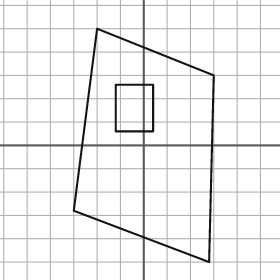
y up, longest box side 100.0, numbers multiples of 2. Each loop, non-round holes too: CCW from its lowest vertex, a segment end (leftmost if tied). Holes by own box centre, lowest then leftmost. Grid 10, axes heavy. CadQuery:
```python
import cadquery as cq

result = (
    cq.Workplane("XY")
    .moveTo(28.0, -50.0)
    .lineTo(30.0, 30.0)
    .lineTo(-20.0, 50.0)
    .lineTo(-30.0, -28.0)
    .close()
    .moveTo(-12.0, 6.0)
    .lineTo(4.0, 6.0)
    .lineTo(4.0, 26.0)
    .lineTo(-12.0, 26.0)
    .close()
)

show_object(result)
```